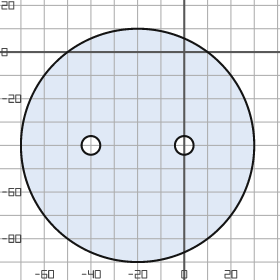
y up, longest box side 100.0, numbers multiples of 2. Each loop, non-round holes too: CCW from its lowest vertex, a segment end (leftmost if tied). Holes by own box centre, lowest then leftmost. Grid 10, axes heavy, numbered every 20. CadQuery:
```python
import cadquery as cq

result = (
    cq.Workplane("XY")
    .moveTo(-20.0, -40.0)
    .circle(50.0)
    .moveTo(-40.0, -40.0)
    .circle(4.0)
    .moveTo(0.0, -40.0)
    .circle(4.0)
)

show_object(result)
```